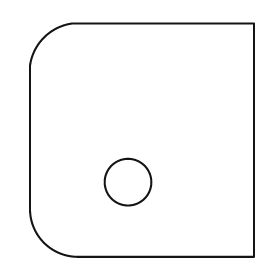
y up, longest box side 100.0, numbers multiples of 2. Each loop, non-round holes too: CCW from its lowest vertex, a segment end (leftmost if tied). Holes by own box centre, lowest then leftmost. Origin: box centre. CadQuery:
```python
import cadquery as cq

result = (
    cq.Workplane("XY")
    .moveTo(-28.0, -50.0)
    .lineTo(48.0, -50.0)
    .lineTo(48.0, 50.0)
    .lineTo(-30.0, 50.0)
    .threePointArc((-42.0, 44.0), (-48.0, 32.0))
    .lineTo(-48.0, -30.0)
    .threePointArc((-42.0, -44.0), (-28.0, -50.0))
    .close()
    .moveTo(-6.0, -18.0)
    .circle(10.0)
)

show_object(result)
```